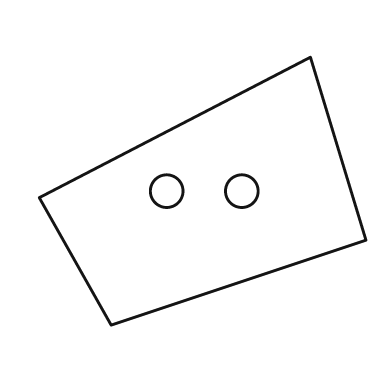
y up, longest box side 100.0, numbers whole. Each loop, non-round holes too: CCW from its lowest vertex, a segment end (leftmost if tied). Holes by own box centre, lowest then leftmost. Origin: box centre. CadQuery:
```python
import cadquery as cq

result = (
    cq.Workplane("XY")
    .moveTo(-28.0, -41.0)
    .lineTo(50.0, -15.0)
    .lineTo(33.0, 41.0)
    .lineTo(-50.0, -2.0)
    .close()
    .moveTo(-11.0, 0.0)
    .circle(5.0)
    .moveTo(12.0, 0.0)
    .circle(5.0)
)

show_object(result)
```